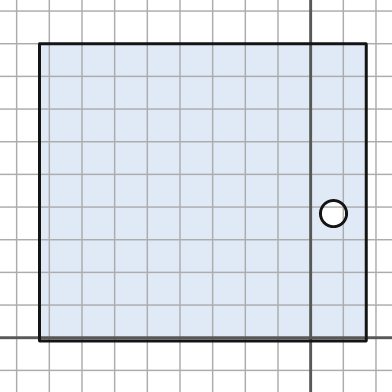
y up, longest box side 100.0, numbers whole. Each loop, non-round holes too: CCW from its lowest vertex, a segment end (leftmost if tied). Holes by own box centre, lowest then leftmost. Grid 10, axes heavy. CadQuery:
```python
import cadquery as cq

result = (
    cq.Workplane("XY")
    .moveTo(-83.0, -1.0)
    .lineTo(17.0, -1.0)
    .lineTo(17.0, 90.0)
    .lineTo(-83.0, 90.0)
    .close()
    .moveTo(7.0, 38.0)
    .circle(4.0)
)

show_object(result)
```